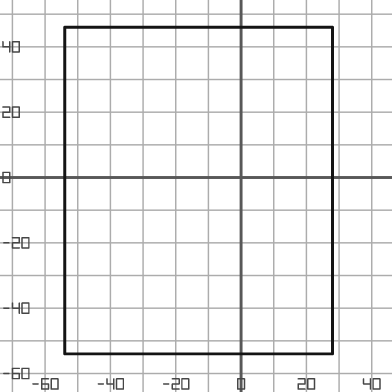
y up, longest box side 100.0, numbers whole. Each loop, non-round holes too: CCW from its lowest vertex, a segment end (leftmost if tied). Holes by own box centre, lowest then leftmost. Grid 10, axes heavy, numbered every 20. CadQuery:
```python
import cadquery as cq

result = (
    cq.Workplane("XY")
    .moveTo(-54.0, -54.0)
    .lineTo(28.0, -54.0)
    .lineTo(28.0, 46.0)
    .lineTo(-54.0, 46.0)
    .close()
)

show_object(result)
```